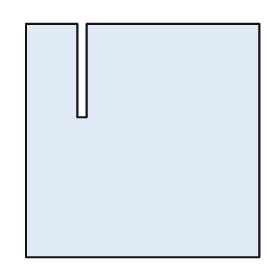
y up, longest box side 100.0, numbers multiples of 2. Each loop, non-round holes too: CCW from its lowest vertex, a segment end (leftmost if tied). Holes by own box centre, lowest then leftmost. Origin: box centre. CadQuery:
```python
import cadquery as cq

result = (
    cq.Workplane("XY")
    .moveTo(-50.0, -50.0)
    .lineTo(50.0, -50.0)
    .lineTo(50.0, 50.0)
    .lineTo(-24.0, 50.0)
    .lineTo(-24.0, 10.0)
    .lineTo(-28.0, 10.0)
    .lineTo(-28.0, 50.0)
    .lineTo(-50.0, 50.0)
    .close()
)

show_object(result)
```